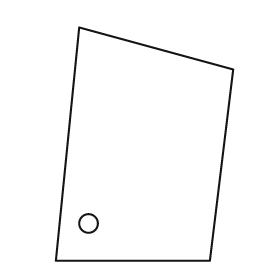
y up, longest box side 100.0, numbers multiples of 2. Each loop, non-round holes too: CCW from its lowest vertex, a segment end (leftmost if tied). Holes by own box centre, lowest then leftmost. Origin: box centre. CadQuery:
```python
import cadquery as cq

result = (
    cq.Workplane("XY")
    .moveTo(-38.0, -50.0)
    .lineTo(28.0, -50.0)
    .lineTo(38.0, 32.0)
    .lineTo(-28.0, 50.0)
    .close()
    .moveTo(-24.0, -34.0)
    .circle(4.0)
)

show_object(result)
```